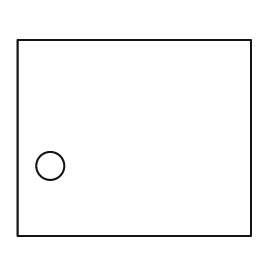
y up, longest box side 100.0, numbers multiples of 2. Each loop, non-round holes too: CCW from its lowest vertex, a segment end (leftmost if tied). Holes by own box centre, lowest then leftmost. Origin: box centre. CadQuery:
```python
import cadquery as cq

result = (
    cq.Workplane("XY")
    .moveTo(-50.0, -42.0)
    .lineTo(50.0, -42.0)
    .lineTo(50.0, 42.0)
    .lineTo(-50.0, 42.0)
    .close()
    .moveTo(-36.0, -12.0)
    .circle(6.0)
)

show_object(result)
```